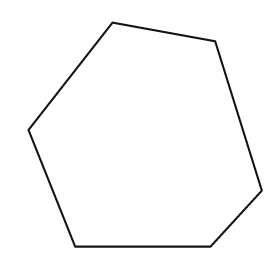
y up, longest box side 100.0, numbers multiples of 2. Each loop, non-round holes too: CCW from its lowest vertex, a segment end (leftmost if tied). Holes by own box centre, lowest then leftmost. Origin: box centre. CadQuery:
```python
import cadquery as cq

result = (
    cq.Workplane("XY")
    .moveTo(-30.0, -48.0)
    .lineTo(28.0, -48.0)
    .lineTo(50.0, -24.0)
    .lineTo(30.0, 40.0)
    .lineTo(-14.0, 48.0)
    .lineTo(-50.0, 2.0)
    .close()
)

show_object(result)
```